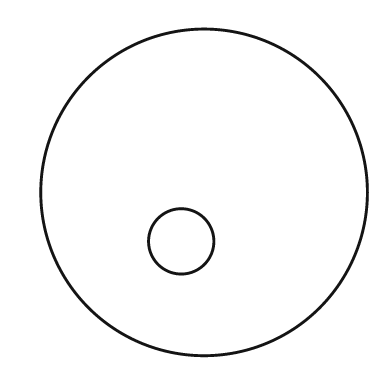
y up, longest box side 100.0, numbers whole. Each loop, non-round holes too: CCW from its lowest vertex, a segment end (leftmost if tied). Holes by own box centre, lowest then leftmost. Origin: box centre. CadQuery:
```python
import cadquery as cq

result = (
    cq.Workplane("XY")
    .moveTo(0.0, 0.0)
    .circle(50.0)
    .moveTo(-7.0, -15.0)
    .circle(10.0)
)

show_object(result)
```